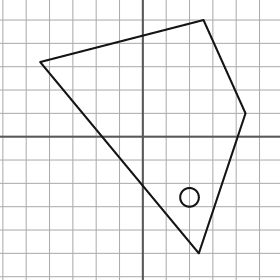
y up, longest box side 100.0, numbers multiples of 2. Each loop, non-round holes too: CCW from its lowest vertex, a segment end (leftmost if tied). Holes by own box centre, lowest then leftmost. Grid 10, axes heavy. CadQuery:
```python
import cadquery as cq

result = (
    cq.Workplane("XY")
    .moveTo(24.0, -50.0)
    .lineTo(44.0, 10.0)
    .lineTo(26.0, 50.0)
    .lineTo(-44.0, 32.0)
    .close()
    .moveTo(20.0, -26.0)
    .circle(4.0)
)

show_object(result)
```